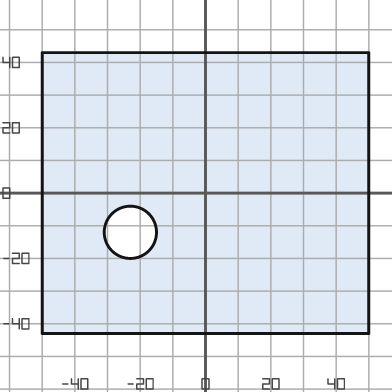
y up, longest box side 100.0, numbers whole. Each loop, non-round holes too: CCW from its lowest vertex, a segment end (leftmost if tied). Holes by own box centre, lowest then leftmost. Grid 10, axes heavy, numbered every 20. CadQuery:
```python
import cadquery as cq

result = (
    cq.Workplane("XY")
    .moveTo(-50.0, -43.0)
    .lineTo(50.0, -43.0)
    .lineTo(50.0, 43.0)
    .lineTo(-50.0, 43.0)
    .close()
    .moveTo(-23.0, -12.0)
    .circle(8.0)
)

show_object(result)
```